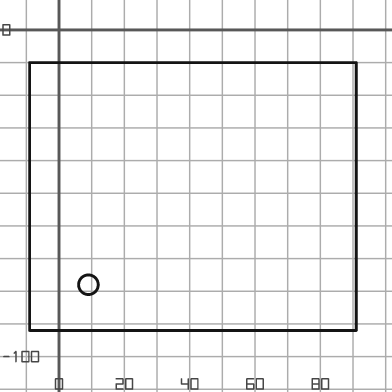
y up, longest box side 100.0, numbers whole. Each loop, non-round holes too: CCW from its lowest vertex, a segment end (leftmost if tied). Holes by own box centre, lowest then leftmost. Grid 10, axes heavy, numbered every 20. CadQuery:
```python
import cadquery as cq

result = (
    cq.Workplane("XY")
    .moveTo(-9.0, -92.0)
    .lineTo(91.0, -92.0)
    .lineTo(91.0, -10.0)
    .lineTo(-9.0, -10.0)
    .close()
    .moveTo(9.0, -78.0)
    .circle(3.0)
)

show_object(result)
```